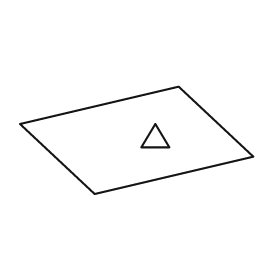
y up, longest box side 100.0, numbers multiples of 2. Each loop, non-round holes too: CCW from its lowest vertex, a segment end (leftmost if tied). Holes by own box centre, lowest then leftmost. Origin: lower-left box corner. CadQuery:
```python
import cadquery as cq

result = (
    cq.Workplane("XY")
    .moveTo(32.0, 0.0)
    .lineTo(100.0, 16.0)
    .lineTo(68.0, 46.0)
    .lineTo(0.0, 30.0)
    .close()
    .moveTo(52.0, 20.0)
    .lineTo(64.0, 20.0)
    .lineTo(58.0, 30.0)
    .close()
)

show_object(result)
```